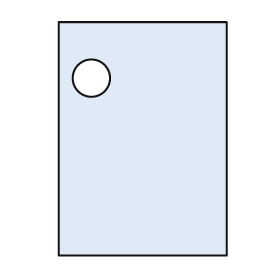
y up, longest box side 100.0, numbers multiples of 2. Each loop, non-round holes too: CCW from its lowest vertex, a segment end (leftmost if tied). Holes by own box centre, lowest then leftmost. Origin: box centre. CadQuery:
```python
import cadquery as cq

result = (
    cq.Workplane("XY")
    .moveTo(-36.0, -50.0)
    .lineTo(36.0, -50.0)
    .lineTo(36.0, 50.0)
    .lineTo(-36.0, 50.0)
    .close()
    .moveTo(-22.0, 26.0)
    .circle(8.0)
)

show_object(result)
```